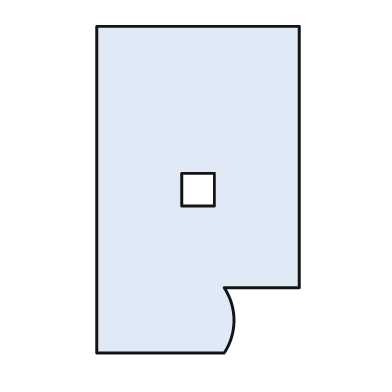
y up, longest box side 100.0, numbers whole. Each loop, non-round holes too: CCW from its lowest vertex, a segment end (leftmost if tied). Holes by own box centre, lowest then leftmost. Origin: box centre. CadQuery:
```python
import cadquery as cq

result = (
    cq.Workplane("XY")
    .moveTo(-31.0, -50.0)
    .lineTo(8.0, -50.0)
    .threePointArc((11.0, -40.0), (8.0, -30.0))
    .lineTo(31.0, -30.0)
    .lineTo(31.0, 50.0)
    .lineTo(-31.0, 50.0)
    .close()
    .moveTo(-5.0, -5.0)
    .lineTo(5.0, -5.0)
    .lineTo(5.0, 5.0)
    .lineTo(-5.0, 5.0)
    .close()
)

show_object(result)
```